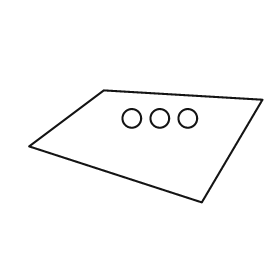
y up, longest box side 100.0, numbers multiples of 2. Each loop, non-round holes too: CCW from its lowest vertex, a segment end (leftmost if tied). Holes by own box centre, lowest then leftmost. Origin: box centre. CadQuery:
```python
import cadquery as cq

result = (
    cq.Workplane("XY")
    .moveTo(24.0, -24.0)
    .lineTo(50.0, 20.0)
    .lineTo(-18.0, 24.0)
    .lineTo(-50.0, 0.0)
    .close()
    .moveTo(-6.0, 12.0)
    .circle(4.0)
    .moveTo(6.0, 12.0)
    .circle(4.0)
    .moveTo(18.0, 12.0)
    .circle(4.0)
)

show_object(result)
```